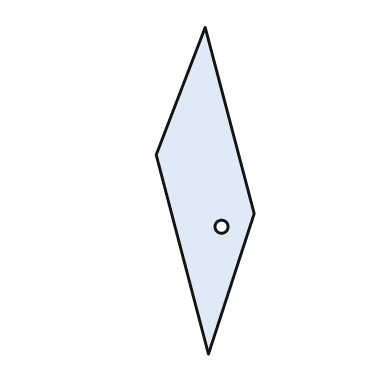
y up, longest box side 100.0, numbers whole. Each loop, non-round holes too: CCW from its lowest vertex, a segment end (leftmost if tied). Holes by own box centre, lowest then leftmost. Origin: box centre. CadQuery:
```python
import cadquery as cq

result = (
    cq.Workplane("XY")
    .moveTo(1.0, -50.0)
    .lineTo(15.0, -7.0)
    .lineTo(0.0, 50.0)
    .lineTo(-15.0, 11.0)
    .close()
    .moveTo(5.0, -11.0)
    .circle(2.0)
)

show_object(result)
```